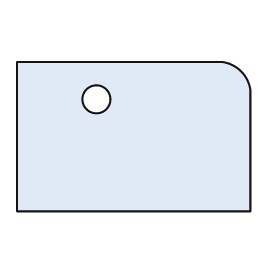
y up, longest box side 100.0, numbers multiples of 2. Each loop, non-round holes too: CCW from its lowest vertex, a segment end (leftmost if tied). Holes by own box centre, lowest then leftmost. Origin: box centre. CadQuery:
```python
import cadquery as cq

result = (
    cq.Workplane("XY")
    .moveTo(-50.0, -32.0)
    .lineTo(50.0, -32.0)
    .lineTo(50.0, 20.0)
    .threePointArc((46.0, 28.0), (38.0, 32.0))
    .lineTo(-50.0, 32.0)
    .close()
    .moveTo(-16.0, 16.0)
    .circle(6.0)
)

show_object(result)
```